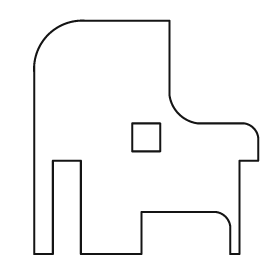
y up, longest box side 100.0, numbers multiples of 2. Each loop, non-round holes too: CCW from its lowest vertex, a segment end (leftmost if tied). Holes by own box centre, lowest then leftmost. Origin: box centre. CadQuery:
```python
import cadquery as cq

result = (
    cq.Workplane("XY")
    .moveTo(-48.0, -50.0)
    .lineTo(-40.0, -50.0)
    .lineTo(-40.0, -10.0)
    .lineTo(-28.0, -10.0)
    .lineTo(-28.0, -50.0)
    .lineTo(-2.0, -50.0)
    .lineTo(-2.0, -32.0)
    .lineTo(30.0, -32.0)
    .threePointArc((34.0, -34.0), (36.0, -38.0))
    .lineTo(36.0, -50.0)
    .lineTo(40.0, -50.0)
    .lineTo(40.0, -10.0)
    .lineTo(48.0, -10.0)
    .lineTo(48.0, 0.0)
    .threePointArc((46.0, 4.0), (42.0, 6.0))
    .lineTo(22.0, 6.0)
    .threePointArc((14.0, 10.0), (10.0, 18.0))
    .lineTo(10.0, 50.0)
    .lineTo(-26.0, 50.0)
    .threePointArc((-42.0, 44.0), (-48.0, 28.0))
    .close()
    .moveTo(-6.0, -6.0)
    .lineTo(6.0, -6.0)
    .lineTo(6.0, 6.0)
    .lineTo(-6.0, 6.0)
    .close()
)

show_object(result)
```